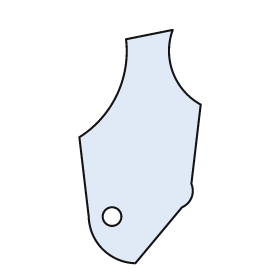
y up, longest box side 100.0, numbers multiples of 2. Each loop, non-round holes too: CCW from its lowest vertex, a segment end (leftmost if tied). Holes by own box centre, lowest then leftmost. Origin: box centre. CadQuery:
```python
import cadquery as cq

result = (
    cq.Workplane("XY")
    .moveTo(-2.0, -50.0)
    .lineTo(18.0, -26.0)
    .threePointArc((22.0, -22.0), (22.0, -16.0))
    .lineTo(26.0, 18.0)
    .threePointArc((14.0, 32.0), (14.0, 50.0))
    .lineTo(-6.0, 46.0)
    .threePointArc((-10.0, 22.0), (-26.0, 4.0))
    .lineTo(-22.0, -30.0)
    .threePointArc((-16.0, -44.0), (-2.0, -50.0))
    .close()
    .moveTo(-12.0, -30.0)
    .circle(4.0)
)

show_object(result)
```